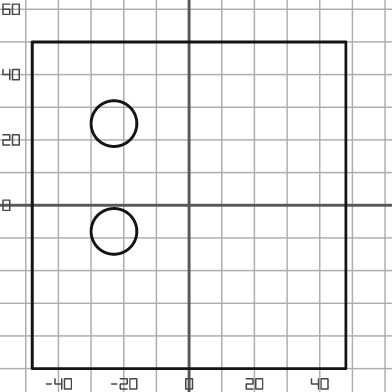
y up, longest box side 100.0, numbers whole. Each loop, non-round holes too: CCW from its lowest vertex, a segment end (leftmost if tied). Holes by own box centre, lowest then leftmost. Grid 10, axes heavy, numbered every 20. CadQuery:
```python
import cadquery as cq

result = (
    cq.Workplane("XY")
    .moveTo(-48.0, -50.0)
    .lineTo(48.0, -50.0)
    .lineTo(48.0, 50.0)
    .lineTo(-48.0, 50.0)
    .close()
    .moveTo(-23.0, -8.0)
    .circle(7.0)
    .moveTo(-23.0, 25.0)
    .circle(7.0)
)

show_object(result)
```